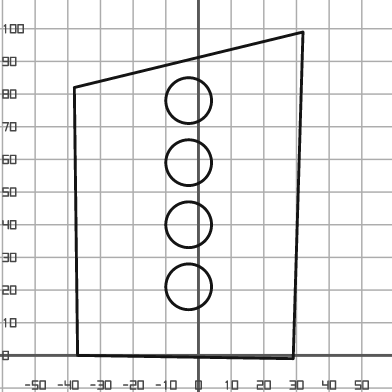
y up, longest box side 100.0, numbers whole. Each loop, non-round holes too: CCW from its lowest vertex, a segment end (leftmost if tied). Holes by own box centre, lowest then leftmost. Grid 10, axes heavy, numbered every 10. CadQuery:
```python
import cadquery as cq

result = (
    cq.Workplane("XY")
    .moveTo(29.0, -1.0)
    .lineTo(32.0, 99.0)
    .lineTo(-38.0, 82.0)
    .lineTo(-37.0, 0.0)
    .close()
    .moveTo(-3.0, 21.0)
    .circle(7.0)
    .moveTo(-3.0, 40.0)
    .circle(7.0)
    .moveTo(-3.0, 59.0)
    .circle(7.0)
    .moveTo(-3.0, 78.0)
    .circle(7.0)
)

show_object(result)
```